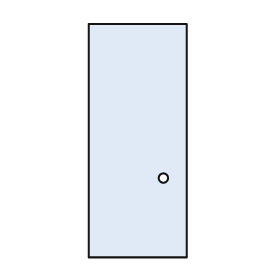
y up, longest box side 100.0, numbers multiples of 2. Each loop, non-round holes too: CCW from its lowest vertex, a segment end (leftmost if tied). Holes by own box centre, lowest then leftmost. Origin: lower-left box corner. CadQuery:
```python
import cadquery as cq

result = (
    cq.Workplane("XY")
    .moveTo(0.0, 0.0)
    .lineTo(42.0, 0.0)
    .lineTo(42.0, 100.0)
    .lineTo(0.0, 100.0)
    .close()
    .moveTo(32.0, 34.0)
    .circle(2.0)
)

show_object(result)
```